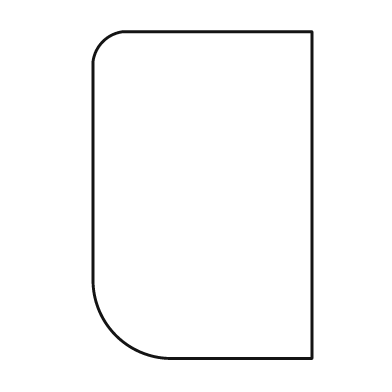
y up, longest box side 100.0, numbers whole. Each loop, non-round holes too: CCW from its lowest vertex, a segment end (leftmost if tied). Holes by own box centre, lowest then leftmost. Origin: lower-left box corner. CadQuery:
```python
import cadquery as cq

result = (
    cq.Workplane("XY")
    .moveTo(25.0, 0.0)
    .lineTo(67.0, 0.0)
    .lineTo(67.0, 100.0)
    .lineTo(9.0, 100.0)
    .threePointArc((3.0, 97.0), (0.0, 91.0))
    .lineTo(0.0, 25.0)
    .threePointArc((7.0, 7.0), (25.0, 0.0))
    .close()
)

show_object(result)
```